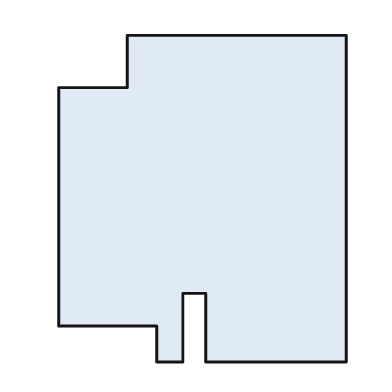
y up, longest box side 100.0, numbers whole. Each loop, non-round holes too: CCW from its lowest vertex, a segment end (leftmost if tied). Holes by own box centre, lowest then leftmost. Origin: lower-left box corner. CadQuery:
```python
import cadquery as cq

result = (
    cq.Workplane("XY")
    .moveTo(30.0, 0.0)
    .lineTo(38.0, 0.0)
    .lineTo(38.0, 21.0)
    .lineTo(45.0, 21.0)
    .lineTo(45.0, 0.0)
    .lineTo(88.0, 0.0)
    .lineTo(88.0, 100.0)
    .lineTo(21.0, 100.0)
    .lineTo(21.0, 84.0)
    .lineTo(0.0, 84.0)
    .lineTo(0.0, 11.0)
    .lineTo(30.0, 11.0)
    .close()
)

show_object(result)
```